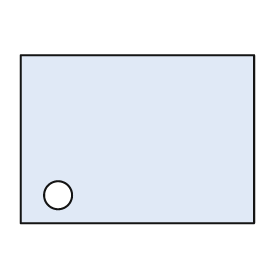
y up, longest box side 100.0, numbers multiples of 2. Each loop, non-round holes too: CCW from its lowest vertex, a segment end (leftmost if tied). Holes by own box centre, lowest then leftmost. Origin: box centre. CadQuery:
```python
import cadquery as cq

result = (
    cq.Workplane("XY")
    .moveTo(-50.0, -36.0)
    .lineTo(50.0, -36.0)
    .lineTo(50.0, 36.0)
    .lineTo(-50.0, 36.0)
    .close()
    .moveTo(-34.0, -24.0)
    .circle(6.0)
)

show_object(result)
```